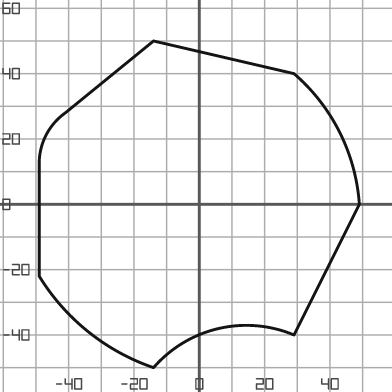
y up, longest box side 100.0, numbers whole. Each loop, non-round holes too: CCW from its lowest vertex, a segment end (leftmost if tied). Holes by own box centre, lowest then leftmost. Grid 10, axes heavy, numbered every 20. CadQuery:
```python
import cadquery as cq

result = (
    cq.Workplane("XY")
    .moveTo(-14.0, -50.0)
    .threePointArc((6.0, -38.0), (29.0, -40.0))
    .lineTo(49.0, 0.0)
    .threePointArc((43.0, 22.0), (29.0, 40.0))
    .lineTo(-14.0, 50.0)
    .lineTo(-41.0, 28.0)
    .threePointArc((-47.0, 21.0), (-49.0, 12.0))
    .lineTo(-49.0, -22.0)
    .threePointArc((-34.0, -39.0), (-14.0, -50.0))
    .close()
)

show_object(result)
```